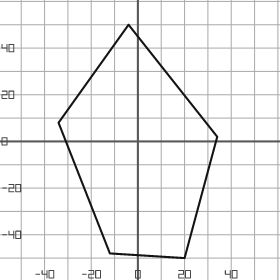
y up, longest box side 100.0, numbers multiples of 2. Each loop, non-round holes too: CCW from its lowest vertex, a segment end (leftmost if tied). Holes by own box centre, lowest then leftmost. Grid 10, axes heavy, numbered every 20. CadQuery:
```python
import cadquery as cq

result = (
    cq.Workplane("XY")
    .moveTo(20.0, -50.0)
    .lineTo(34.0, 2.0)
    .lineTo(-4.0, 50.0)
    .lineTo(-34.0, 8.0)
    .lineTo(-12.0, -48.0)
    .close()
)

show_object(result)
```